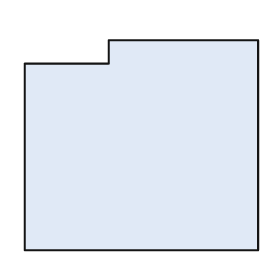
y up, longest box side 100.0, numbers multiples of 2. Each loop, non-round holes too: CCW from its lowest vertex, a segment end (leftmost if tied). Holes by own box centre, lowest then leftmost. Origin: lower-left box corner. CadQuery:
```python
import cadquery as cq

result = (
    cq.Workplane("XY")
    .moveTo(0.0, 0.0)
    .lineTo(100.0, 0.0)
    .lineTo(100.0, 90.0)
    .lineTo(36.0, 90.0)
    .lineTo(36.0, 80.0)
    .lineTo(0.0, 80.0)
    .close()
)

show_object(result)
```